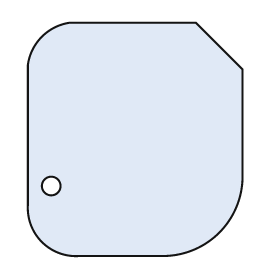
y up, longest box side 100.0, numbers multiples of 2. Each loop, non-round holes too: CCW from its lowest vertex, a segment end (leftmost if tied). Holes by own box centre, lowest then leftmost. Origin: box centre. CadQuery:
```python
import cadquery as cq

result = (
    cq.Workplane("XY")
    .moveTo(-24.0, -50.0)
    .lineTo(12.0, -50.0)
    .threePointArc((36.0, -40.0), (46.0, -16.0))
    .lineTo(46.0, 30.0)
    .lineTo(26.0, 50.0)
    .lineTo(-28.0, 50.0)
    .threePointArc((-40.0, 44.0), (-46.0, 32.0))
    .lineTo(-46.0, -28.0)
    .threePointArc((-40.0, -44.0), (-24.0, -50.0))
    .close()
    .moveTo(-36.0, -20.0)
    .circle(4.0)
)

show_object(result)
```